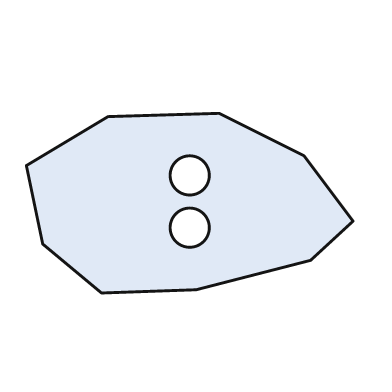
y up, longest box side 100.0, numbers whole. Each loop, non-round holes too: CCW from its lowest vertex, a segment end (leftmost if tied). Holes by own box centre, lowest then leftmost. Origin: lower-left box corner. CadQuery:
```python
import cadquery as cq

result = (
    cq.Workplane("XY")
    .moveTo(23.0, 0.0)
    .lineTo(52.0, 1.0)
    .lineTo(87.0, 10.0)
    .lineTo(100.0, 22.0)
    .lineTo(85.0, 42.0)
    .lineTo(59.0, 55.0)
    .lineTo(25.0, 54.0)
    .lineTo(0.0, 39.0)
    .lineTo(5.0, 15.0)
    .close()
    .moveTo(50.0, 20.0)
    .circle(6.0)
    .moveTo(50.0, 36.0)
    .circle(6.0)
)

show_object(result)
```